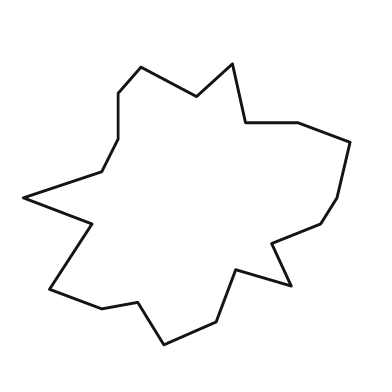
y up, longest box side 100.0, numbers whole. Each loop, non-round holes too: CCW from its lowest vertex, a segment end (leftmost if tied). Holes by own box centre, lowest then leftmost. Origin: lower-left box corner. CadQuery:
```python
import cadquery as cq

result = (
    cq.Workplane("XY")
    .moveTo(43.0, 0.0)
    .lineTo(59.0, 7.0)
    .lineTo(65.0, 23.0)
    .lineTo(82.0, 18.0)
    .lineTo(76.0, 31.0)
    .lineTo(91.0, 37.0)
    .lineTo(96.0, 45.0)
    .lineTo(100.0, 62.0)
    .lineTo(84.0, 68.0)
    .lineTo(68.0, 68.0)
    .lineTo(64.0, 86.0)
    .lineTo(53.0, 76.0)
    .lineTo(36.0, 85.0)
    .lineTo(29.0, 77.0)
    .lineTo(29.0, 63.0)
    .lineTo(24.0, 53.0)
    .lineTo(0.0, 45.0)
    .lineTo(21.0, 37.0)
    .lineTo(8.0, 17.0)
    .lineTo(24.0, 11.0)
    .lineTo(35.0, 13.0)
    .close()
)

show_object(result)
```